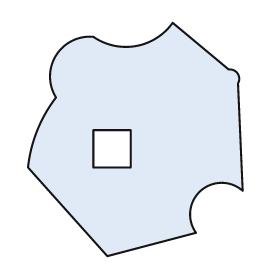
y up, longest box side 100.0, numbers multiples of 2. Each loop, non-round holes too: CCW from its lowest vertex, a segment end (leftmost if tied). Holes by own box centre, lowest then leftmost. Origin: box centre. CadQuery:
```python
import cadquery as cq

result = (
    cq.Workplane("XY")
    .moveTo(-12.0, -50.0)
    .lineTo(26.0, -40.0)
    .threePointArc((28.0, -22.0), (46.0, -22.0))
    .lineTo(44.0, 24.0)
    .threePointArc((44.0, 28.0), (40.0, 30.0))
    .lineTo(16.0, 50.0)
    .threePointArc((0.0, 40.0), (-18.0, 44.0))
    .threePointArc((-34.0, 36.0), (-34.0, 18.0))
    .threePointArc((-42.0, 4.0), (-46.0, -12.0))
    .close()
    .moveTo(-18.0, -12.0)
    .lineTo(-2.0, -12.0)
    .lineTo(-2.0, 4.0)
    .lineTo(-18.0, 4.0)
    .close()
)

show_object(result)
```